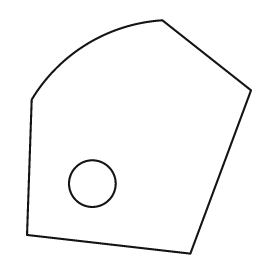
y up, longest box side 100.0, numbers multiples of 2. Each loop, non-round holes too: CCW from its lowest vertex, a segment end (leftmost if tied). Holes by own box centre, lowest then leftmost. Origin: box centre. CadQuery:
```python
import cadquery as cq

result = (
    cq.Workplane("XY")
    .moveTo(22.0, -50.0)
    .lineTo(48.0, 20.0)
    .lineTo(10.0, 50.0)
    .threePointArc((-22.0, 40.0), (-46.0, 16.0))
    .lineTo(-48.0, -42.0)
    .close()
    .moveTo(-20.0, -20.0)
    .circle(10.0)
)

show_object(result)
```